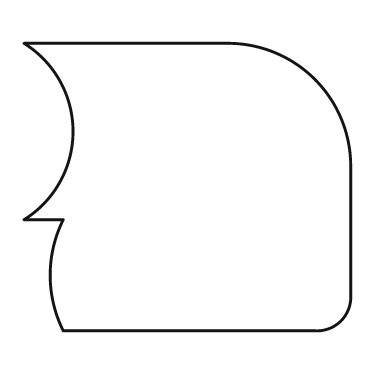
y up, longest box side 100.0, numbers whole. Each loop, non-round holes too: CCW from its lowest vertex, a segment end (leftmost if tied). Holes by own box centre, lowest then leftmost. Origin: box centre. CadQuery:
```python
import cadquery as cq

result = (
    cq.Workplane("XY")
    .moveTo(-38.0, -44.0)
    .lineTo(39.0, -44.0)
    .threePointArc((47.0, -41.0), (50.0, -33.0))
    .lineTo(50.0, 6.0)
    .threePointArc((39.0, 33.0), (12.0, 44.0))
    .lineTo(-50.0, 44.0)
    .threePointArc((-35.0, 17.0), (-50.0, -10.0))
    .lineTo(-38.0, -10.0)
    .threePointArc((-42.0, -27.0), (-38.0, -44.0))
    .close()
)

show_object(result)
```